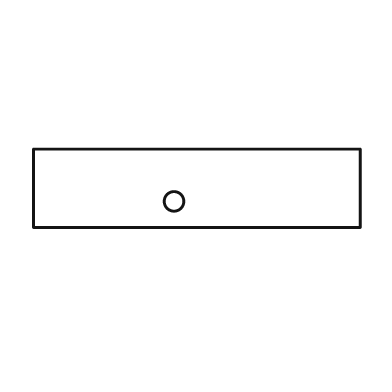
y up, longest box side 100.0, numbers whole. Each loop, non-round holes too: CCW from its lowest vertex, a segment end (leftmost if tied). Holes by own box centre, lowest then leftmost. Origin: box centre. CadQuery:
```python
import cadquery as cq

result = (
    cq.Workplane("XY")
    .moveTo(-50.0, -12.0)
    .lineTo(50.0, -12.0)
    .lineTo(50.0, 12.0)
    .lineTo(-50.0, 12.0)
    .close()
    .moveTo(-7.0, -4.0)
    .circle(3.0)
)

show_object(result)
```